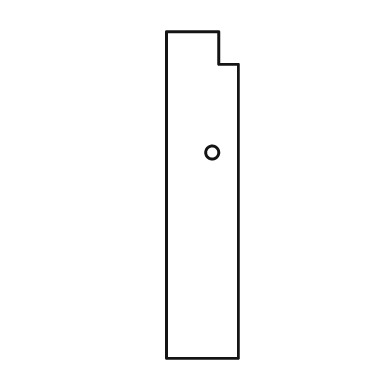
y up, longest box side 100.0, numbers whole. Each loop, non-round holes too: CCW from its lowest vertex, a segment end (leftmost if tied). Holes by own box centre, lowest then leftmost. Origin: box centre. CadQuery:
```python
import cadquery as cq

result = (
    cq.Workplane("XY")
    .moveTo(-11.0, -50.0)
    .lineTo(11.0, -50.0)
    .lineTo(11.0, 40.0)
    .lineTo(5.0, 40.0)
    .lineTo(5.0, 50.0)
    .lineTo(-11.0, 50.0)
    .close()
    .moveTo(3.0, 13.0)
    .circle(2.0)
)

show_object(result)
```